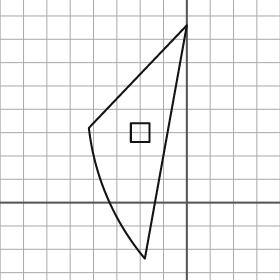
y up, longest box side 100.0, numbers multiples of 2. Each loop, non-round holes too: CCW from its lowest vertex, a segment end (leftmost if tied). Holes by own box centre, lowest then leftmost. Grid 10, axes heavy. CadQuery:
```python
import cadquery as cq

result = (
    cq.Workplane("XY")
    .moveTo(-18.0, -24.0)
    .lineTo(0.0, 76.0)
    .lineTo(-42.0, 32.0)
    .threePointArc((-34.0, 2.0), (-18.0, -24.0))
    .close()
    .moveTo(-24.0, 26.0)
    .lineTo(-16.0, 26.0)
    .lineTo(-16.0, 34.0)
    .lineTo(-24.0, 34.0)
    .close()
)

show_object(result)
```